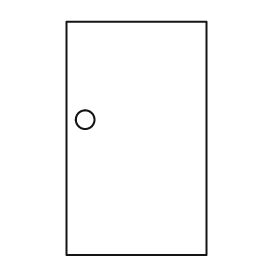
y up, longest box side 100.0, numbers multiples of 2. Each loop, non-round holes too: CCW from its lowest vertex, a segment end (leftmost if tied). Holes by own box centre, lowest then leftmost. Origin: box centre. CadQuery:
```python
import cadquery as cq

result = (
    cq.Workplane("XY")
    .moveTo(-30.0, -50.0)
    .lineTo(30.0, -50.0)
    .lineTo(30.0, 50.0)
    .lineTo(-30.0, 50.0)
    .close()
    .moveTo(-22.0, 8.0)
    .circle(4.0)
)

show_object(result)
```